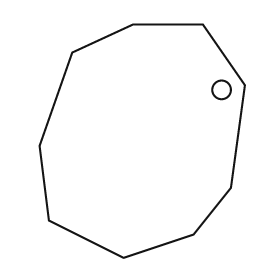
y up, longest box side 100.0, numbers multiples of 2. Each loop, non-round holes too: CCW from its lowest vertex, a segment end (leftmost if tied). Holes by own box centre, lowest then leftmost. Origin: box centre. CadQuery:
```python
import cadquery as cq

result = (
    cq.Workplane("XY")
    .moveTo(-8.0, -50.0)
    .lineTo(22.0, -40.0)
    .lineTo(38.0, -20.0)
    .lineTo(44.0, 24.0)
    .lineTo(26.0, 50.0)
    .lineTo(-4.0, 50.0)
    .lineTo(-30.0, 38.0)
    .lineTo(-44.0, -2.0)
    .lineTo(-40.0, -34.0)
    .close()
    .moveTo(34.0, 22.0)
    .circle(4.0)
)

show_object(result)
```